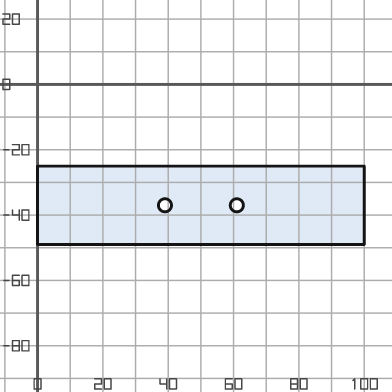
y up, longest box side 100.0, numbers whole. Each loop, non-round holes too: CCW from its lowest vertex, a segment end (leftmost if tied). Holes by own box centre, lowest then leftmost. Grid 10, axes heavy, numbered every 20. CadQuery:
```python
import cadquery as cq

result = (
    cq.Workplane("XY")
    .moveTo(0.0, -49.0)
    .lineTo(100.0, -49.0)
    .lineTo(100.0, -25.0)
    .lineTo(0.0, -25.0)
    .close()
    .moveTo(39.0, -37.0)
    .circle(2.0)
    .moveTo(61.0, -37.0)
    .circle(2.0)
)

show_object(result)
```